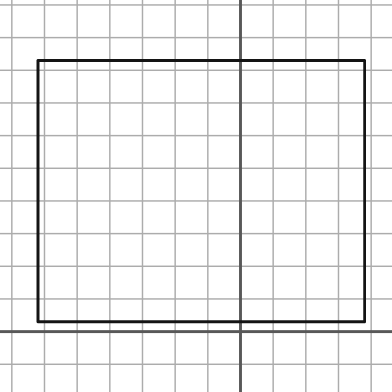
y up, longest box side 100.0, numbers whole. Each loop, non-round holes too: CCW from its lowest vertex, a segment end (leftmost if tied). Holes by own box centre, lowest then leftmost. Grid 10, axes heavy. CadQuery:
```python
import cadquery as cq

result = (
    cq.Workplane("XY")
    .moveTo(-62.0, 3.0)
    .lineTo(38.0, 3.0)
    .lineTo(38.0, 83.0)
    .lineTo(-62.0, 83.0)
    .close()
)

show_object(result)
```